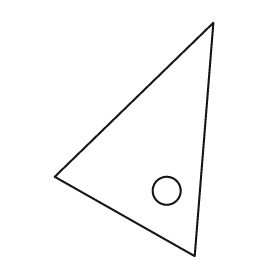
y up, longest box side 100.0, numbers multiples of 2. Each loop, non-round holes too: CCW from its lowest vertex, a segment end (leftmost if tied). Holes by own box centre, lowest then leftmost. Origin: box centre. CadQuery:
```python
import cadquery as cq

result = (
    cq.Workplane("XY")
    .moveTo(26.0, -50.0)
    .lineTo(34.0, 50.0)
    .lineTo(-34.0, -16.0)
    .close()
    .moveTo(14.0, -22.0)
    .circle(6.0)
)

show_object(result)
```